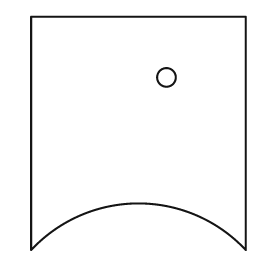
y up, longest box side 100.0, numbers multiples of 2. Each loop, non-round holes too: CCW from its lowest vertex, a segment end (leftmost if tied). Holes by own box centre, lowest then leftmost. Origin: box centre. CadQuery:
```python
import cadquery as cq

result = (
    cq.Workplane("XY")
    .moveTo(-46.0, -50.0)
    .threePointArc((0.0, -30.0), (46.0, -50.0))
    .lineTo(46.0, 50.0)
    .lineTo(-46.0, 50.0)
    .close()
    .moveTo(12.0, 24.0)
    .circle(4.0)
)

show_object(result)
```